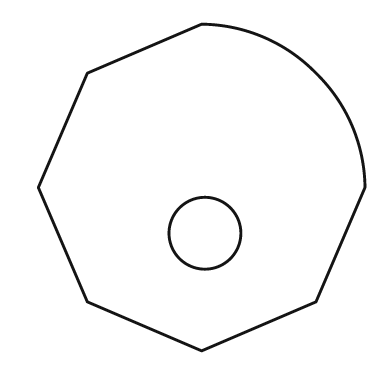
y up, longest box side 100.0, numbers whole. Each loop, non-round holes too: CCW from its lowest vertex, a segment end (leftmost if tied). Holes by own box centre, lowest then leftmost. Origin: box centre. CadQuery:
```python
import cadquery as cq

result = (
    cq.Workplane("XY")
    .moveTo(0.0, -50.0)
    .lineTo(35.0, -35.0)
    .lineTo(50.0, 0.0)
    .threePointArc((46.0, 19.0), (35.0, 35.0))
    .threePointArc((19.0, 46.0), (0.0, 50.0))
    .lineTo(-35.0, 35.0)
    .lineTo(-50.0, 0.0)
    .lineTo(-35.0, -35.0)
    .close()
    .moveTo(1.0, -14.0)
    .circle(11.0)
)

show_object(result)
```